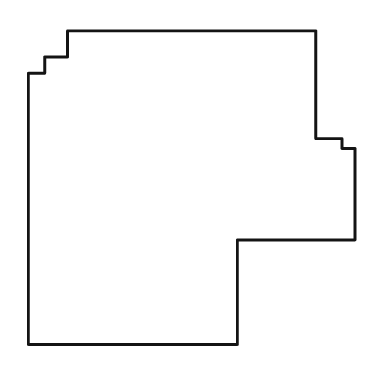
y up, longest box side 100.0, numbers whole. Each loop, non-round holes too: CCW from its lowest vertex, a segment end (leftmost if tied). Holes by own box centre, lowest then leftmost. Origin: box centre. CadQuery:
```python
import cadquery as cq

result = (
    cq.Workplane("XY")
    .moveTo(-50.0, -48.0)
    .lineTo(14.0, -48.0)
    .lineTo(14.0, -16.0)
    .lineTo(50.0, -16.0)
    .lineTo(50.0, 12.0)
    .lineTo(46.0, 12.0)
    .lineTo(46.0, 15.0)
    .lineTo(38.0, 15.0)
    .lineTo(38.0, 48.0)
    .lineTo(-38.0, 48.0)
    .lineTo(-38.0, 40.0)
    .lineTo(-45.0, 40.0)
    .lineTo(-45.0, 35.0)
    .lineTo(-50.0, 35.0)
    .close()
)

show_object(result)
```